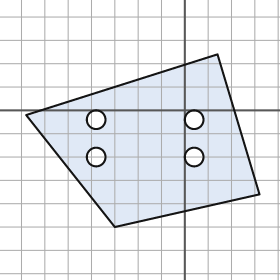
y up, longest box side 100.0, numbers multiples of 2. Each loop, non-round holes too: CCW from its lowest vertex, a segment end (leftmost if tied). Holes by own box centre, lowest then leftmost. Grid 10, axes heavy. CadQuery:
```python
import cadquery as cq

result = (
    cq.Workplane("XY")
    .moveTo(-30.0, -50.0)
    .lineTo(32.0, -36.0)
    .lineTo(14.0, 24.0)
    .lineTo(-68.0, -2.0)
    .close()
    .moveTo(-38.0, -20.0)
    .circle(4.0)
    .moveTo(4.0, -20.0)
    .circle(4.0)
    .moveTo(-38.0, -4.0)
    .circle(4.0)
    .moveTo(4.0, -4.0)
    .circle(4.0)
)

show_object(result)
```